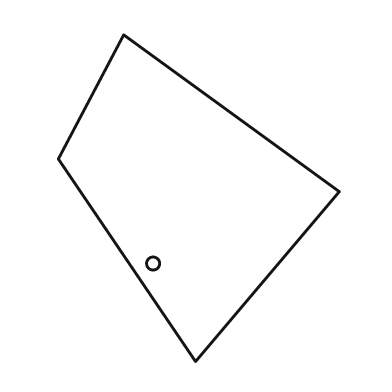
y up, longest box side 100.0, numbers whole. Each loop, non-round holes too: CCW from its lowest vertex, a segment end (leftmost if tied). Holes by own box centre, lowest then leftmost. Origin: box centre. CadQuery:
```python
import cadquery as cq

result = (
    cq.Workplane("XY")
    .moveTo(-1.0, -50.0)
    .lineTo(43.0, 2.0)
    .lineTo(-23.0, 50.0)
    .lineTo(-43.0, 12.0)
    .close()
    .moveTo(-14.0, -20.0)
    .circle(2.0)
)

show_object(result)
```